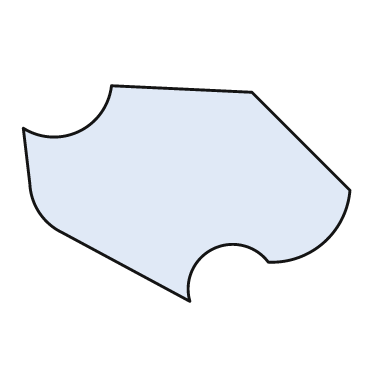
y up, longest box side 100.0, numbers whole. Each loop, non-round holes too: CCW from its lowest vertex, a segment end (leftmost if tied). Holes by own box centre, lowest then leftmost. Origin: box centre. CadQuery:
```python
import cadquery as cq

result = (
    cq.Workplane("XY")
    .moveTo(1.0, -33.0)
    .threePointArc((8.0, -17.0), (25.0, -21.0))
    .threePointArc((42.0, -15.0), (50.0, 1.0))
    .lineTo(20.0, 31.0)
    .lineTo(-23.0, 33.0)
    .threePointArc((-33.0, 19.0), (-50.0, 20.0))
    .lineTo(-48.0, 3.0)
    .threePointArc((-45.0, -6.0), (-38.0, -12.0))
    .close()
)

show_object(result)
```